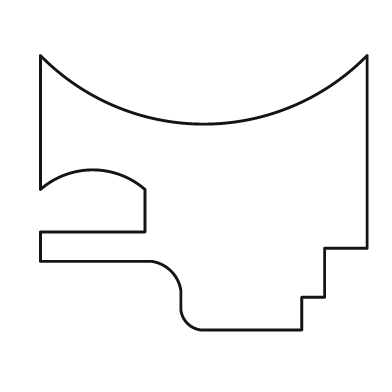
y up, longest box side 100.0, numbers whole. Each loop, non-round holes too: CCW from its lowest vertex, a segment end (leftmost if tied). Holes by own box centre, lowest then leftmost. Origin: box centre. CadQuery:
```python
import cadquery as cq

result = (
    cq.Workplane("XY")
    .moveTo(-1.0, -42.0)
    .lineTo(30.0, -42.0)
    .lineTo(30.0, -32.0)
    .lineTo(37.0, -32.0)
    .lineTo(37.0, -17.0)
    .lineTo(50.0, -17.0)
    .lineTo(50.0, 42.0)
    .threePointArc((0.0, 21.0), (-50.0, 42.0))
    .lineTo(-50.0, 1.0)
    .threePointArc((-34.0, 7.0), (-18.0, 1.0))
    .lineTo(-18.0, -12.0)
    .lineTo(-50.0, -12.0)
    .lineTo(-50.0, -21.0)
    .lineTo(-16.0, -21.0)
    .threePointArc((-10.0, -24.0), (-7.0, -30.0))
    .lineTo(-7.0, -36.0)
    .threePointArc((-5.0, -40.0), (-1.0, -42.0))
    .close()
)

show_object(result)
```